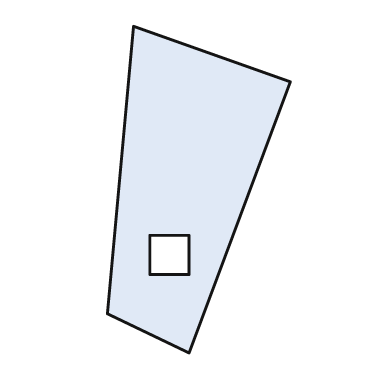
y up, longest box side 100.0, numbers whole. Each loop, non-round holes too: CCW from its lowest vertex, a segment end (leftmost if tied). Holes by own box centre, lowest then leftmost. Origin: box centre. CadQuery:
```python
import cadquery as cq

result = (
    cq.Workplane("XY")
    .moveTo(-3.0, -50.0)
    .lineTo(28.0, 33.0)
    .lineTo(-20.0, 50.0)
    .lineTo(-28.0, -38.0)
    .close()
    .moveTo(-15.0, -26.0)
    .lineTo(-3.0, -26.0)
    .lineTo(-3.0, -14.0)
    .lineTo(-15.0, -14.0)
    .close()
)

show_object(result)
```